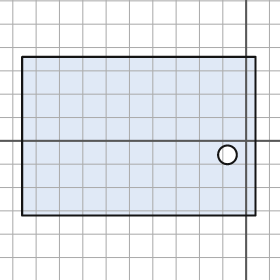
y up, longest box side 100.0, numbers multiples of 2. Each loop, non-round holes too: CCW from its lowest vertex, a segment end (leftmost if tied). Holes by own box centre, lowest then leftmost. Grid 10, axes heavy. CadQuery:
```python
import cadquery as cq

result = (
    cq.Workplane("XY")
    .moveTo(-96.0, -32.0)
    .lineTo(4.0, -32.0)
    .lineTo(4.0, 36.0)
    .lineTo(-96.0, 36.0)
    .close()
    .moveTo(-8.0, -6.0)
    .circle(4.0)
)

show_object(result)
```